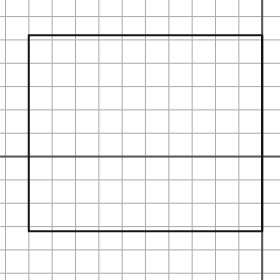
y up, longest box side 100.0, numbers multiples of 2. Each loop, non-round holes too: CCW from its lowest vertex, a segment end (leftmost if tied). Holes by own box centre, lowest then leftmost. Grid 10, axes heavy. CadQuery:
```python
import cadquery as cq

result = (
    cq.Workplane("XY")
    .moveTo(-100.0, -32.0)
    .lineTo(0.0, -32.0)
    .lineTo(0.0, 52.0)
    .lineTo(-100.0, 52.0)
    .close()
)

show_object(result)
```